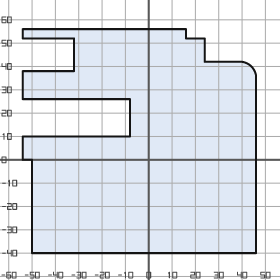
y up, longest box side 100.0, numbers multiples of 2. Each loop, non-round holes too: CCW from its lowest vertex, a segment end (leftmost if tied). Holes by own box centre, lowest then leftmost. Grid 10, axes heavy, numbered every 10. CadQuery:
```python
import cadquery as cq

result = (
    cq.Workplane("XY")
    .moveTo(-50.0, -40.0)
    .lineTo(46.0, -40.0)
    .lineTo(46.0, 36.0)
    .threePointArc((44.0, 40.0), (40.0, 42.0))
    .lineTo(24.0, 42.0)
    .lineTo(24.0, 52.0)
    .lineTo(16.0, 52.0)
    .lineTo(16.0, 56.0)
    .lineTo(-54.0, 56.0)
    .lineTo(-54.0, 52.0)
    .lineTo(-32.0, 52.0)
    .lineTo(-32.0, 38.0)
    .lineTo(-54.0, 38.0)
    .lineTo(-54.0, 26.0)
    .lineTo(-8.0, 26.0)
    .lineTo(-8.0, 10.0)
    .lineTo(-54.0, 10.0)
    .lineTo(-54.0, 0.0)
    .lineTo(-50.0, 0.0)
    .close()
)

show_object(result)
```